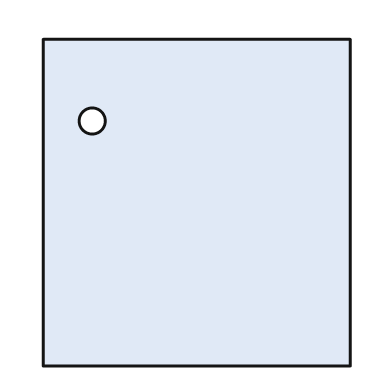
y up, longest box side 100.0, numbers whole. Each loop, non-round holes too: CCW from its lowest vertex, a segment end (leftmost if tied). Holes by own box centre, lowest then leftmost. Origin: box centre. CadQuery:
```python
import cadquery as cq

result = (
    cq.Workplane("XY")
    .moveTo(-47.0, -50.0)
    .lineTo(47.0, -50.0)
    .lineTo(47.0, 50.0)
    .lineTo(-47.0, 50.0)
    .close()
    .moveTo(-32.0, 25.0)
    .circle(4.0)
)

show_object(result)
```